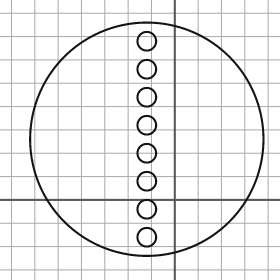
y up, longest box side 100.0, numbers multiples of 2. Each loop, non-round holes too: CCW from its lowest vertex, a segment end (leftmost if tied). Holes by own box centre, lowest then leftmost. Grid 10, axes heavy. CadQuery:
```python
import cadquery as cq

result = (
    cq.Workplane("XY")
    .moveTo(-12.0, 26.0)
    .circle(50.0)
    .moveTo(-12.0, -16.0)
    .circle(4.0)
    .moveTo(-12.0, -4.0)
    .circle(4.0)
    .moveTo(-12.0, 8.0)
    .circle(4.0)
    .moveTo(-12.0, 20.0)
    .circle(4.0)
    .moveTo(-12.0, 32.0)
    .circle(4.0)
    .moveTo(-12.0, 44.0)
    .circle(4.0)
    .moveTo(-12.0, 56.0)
    .circle(4.0)
    .moveTo(-12.0, 68.0)
    .circle(4.0)
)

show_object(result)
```